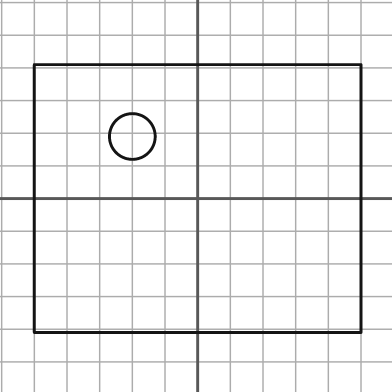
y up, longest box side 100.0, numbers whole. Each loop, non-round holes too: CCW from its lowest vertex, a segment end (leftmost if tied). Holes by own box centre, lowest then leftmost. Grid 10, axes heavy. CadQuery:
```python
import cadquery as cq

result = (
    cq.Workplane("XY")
    .moveTo(-50.0, -41.0)
    .lineTo(50.0, -41.0)
    .lineTo(50.0, 41.0)
    .lineTo(-50.0, 41.0)
    .close()
    .moveTo(-20.0, 19.0)
    .circle(7.0)
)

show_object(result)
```